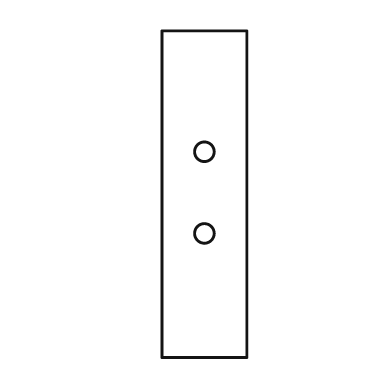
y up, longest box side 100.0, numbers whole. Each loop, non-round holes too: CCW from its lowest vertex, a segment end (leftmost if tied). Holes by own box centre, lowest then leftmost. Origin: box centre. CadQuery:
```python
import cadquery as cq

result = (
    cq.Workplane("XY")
    .moveTo(-13.0, -50.0)
    .lineTo(13.0, -50.0)
    .lineTo(13.0, 50.0)
    .lineTo(-13.0, 50.0)
    .close()
    .moveTo(0.0, -12.0)
    .circle(3.0)
    .moveTo(0.0, 13.0)
    .circle(3.0)
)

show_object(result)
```